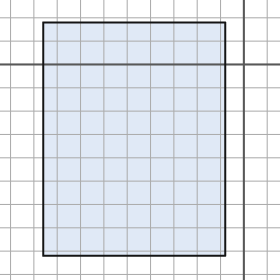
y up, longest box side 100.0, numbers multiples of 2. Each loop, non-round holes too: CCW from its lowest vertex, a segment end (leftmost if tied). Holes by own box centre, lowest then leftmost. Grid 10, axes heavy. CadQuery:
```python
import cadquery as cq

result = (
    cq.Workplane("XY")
    .moveTo(-86.0, -82.0)
    .lineTo(-8.0, -82.0)
    .lineTo(-8.0, 18.0)
    .lineTo(-86.0, 18.0)
    .close()
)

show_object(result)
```